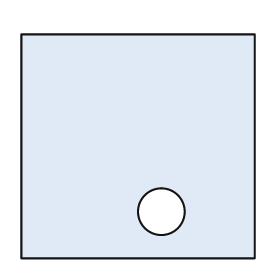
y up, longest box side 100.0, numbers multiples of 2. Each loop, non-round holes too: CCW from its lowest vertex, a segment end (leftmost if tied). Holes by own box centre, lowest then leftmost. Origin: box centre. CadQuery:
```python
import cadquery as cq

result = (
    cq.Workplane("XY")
    .moveTo(-50.0, -48.0)
    .lineTo(50.0, -48.0)
    .lineTo(50.0, 48.0)
    .lineTo(-50.0, 48.0)
    .close()
    .moveTo(10.0, -28.0)
    .circle(10.0)
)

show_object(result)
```